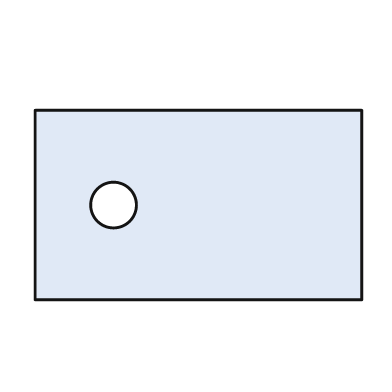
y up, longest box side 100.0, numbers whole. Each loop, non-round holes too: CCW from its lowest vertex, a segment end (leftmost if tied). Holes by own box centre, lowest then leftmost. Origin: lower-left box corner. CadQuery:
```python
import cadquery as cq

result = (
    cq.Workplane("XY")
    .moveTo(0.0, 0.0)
    .lineTo(100.0, 0.0)
    .lineTo(100.0, 58.0)
    .lineTo(0.0, 58.0)
    .close()
    .moveTo(24.0, 29.0)
    .circle(7.0)
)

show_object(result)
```